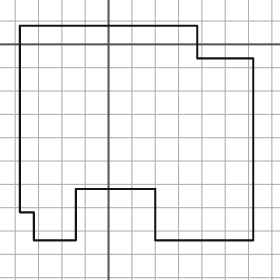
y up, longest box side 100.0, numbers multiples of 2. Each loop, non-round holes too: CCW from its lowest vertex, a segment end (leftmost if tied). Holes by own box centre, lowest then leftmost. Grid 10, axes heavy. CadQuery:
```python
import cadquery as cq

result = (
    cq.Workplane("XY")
    .moveTo(-32.0, -84.0)
    .lineTo(-14.0, -84.0)
    .lineTo(-14.0, -62.0)
    .lineTo(20.0, -62.0)
    .lineTo(20.0, -84.0)
    .lineTo(62.0, -84.0)
    .lineTo(62.0, -6.0)
    .lineTo(38.0, -6.0)
    .lineTo(38.0, 8.0)
    .lineTo(-38.0, 8.0)
    .lineTo(-38.0, -72.0)
    .lineTo(-32.0, -72.0)
    .close()
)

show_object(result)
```